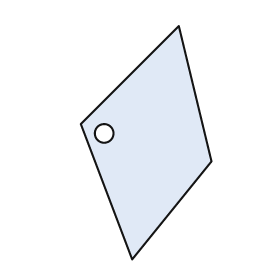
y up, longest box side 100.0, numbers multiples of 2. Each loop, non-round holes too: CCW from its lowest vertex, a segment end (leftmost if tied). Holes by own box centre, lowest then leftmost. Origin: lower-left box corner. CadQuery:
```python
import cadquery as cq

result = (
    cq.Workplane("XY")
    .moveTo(22.0, 0.0)
    .lineTo(56.0, 42.0)
    .lineTo(42.0, 100.0)
    .lineTo(0.0, 58.0)
    .close()
    .moveTo(10.0, 54.0)
    .circle(4.0)
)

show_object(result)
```